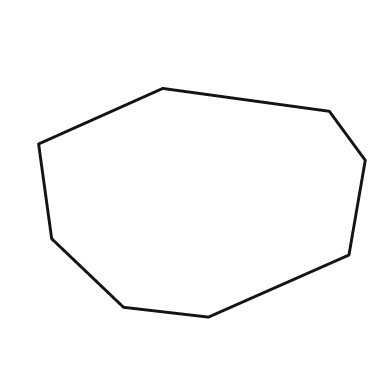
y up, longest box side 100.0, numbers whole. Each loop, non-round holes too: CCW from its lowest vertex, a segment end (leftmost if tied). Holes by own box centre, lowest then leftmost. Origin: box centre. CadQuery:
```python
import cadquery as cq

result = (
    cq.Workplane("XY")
    .moveTo(2.0, -35.0)
    .lineTo(45.0, -16.0)
    .lineTo(50.0, 13.0)
    .lineTo(39.0, 28.0)
    .lineTo(-12.0, 35.0)
    .lineTo(-50.0, 18.0)
    .lineTo(-46.0, -11.0)
    .lineTo(-24.0, -32.0)
    .close()
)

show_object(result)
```